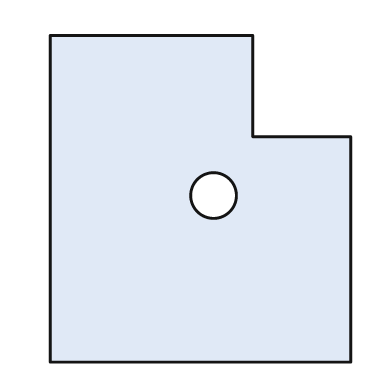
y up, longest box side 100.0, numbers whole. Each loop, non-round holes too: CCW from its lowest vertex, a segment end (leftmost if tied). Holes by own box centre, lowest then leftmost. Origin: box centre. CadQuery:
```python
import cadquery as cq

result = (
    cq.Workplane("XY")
    .moveTo(-46.0, -50.0)
    .lineTo(46.0, -50.0)
    .lineTo(46.0, 19.0)
    .lineTo(16.0, 19.0)
    .lineTo(16.0, 50.0)
    .lineTo(-46.0, 50.0)
    .close()
    .moveTo(4.0, 1.0)
    .circle(7.0)
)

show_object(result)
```